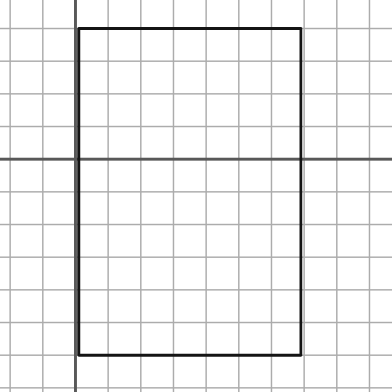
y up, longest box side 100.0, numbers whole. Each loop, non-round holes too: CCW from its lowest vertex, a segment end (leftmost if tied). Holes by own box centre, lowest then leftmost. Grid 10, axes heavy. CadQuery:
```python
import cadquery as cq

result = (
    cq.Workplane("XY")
    .moveTo(1.0, -60.0)
    .lineTo(69.0, -60.0)
    .lineTo(69.0, 40.0)
    .lineTo(1.0, 40.0)
    .close()
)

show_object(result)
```